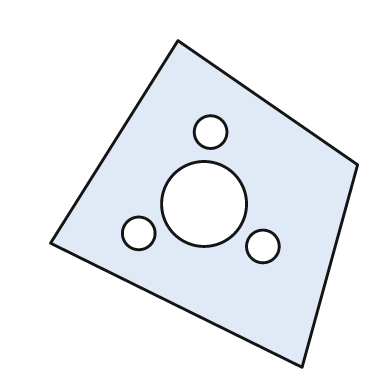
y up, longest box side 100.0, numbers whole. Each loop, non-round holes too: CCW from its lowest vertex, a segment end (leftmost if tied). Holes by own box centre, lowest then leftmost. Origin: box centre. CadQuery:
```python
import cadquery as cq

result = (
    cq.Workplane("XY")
    .moveTo(30.0, -50.0)
    .lineTo(47.0, 12.0)
    .lineTo(-8.0, 50.0)
    .lineTo(-47.0, -12.0)
    .close()
    .moveTo(18.0, -13.0)
    .circle(5.0)
    .moveTo(-20.0, -9.0)
    .circle(5.0)
    .moveTo(0.0, 0.0)
    .circle(13.0)
    .moveTo(2.0, 22.0)
    .circle(5.0)
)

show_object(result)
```